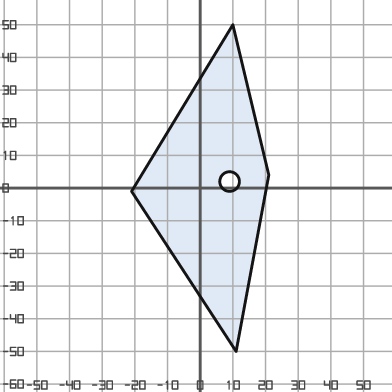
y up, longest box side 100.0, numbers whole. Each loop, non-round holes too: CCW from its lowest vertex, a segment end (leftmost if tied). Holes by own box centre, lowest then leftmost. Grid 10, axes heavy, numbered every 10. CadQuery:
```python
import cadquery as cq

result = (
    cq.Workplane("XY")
    .moveTo(11.0, -50.0)
    .lineTo(21.0, 4.0)
    .lineTo(10.0, 50.0)
    .lineTo(-21.0, -1.0)
    .close()
    .moveTo(9.0, 2.0)
    .circle(3.0)
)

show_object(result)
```